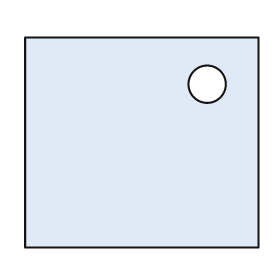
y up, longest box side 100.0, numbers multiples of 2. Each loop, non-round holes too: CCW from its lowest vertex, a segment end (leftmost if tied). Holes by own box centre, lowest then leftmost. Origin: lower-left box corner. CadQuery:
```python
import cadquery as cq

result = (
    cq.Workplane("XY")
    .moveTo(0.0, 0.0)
    .lineTo(100.0, 0.0)
    .lineTo(100.0, 90.0)
    .lineTo(0.0, 90.0)
    .close()
    .moveTo(78.0, 70.0)
    .circle(8.0)
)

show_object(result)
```